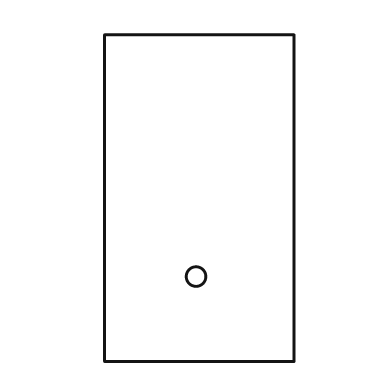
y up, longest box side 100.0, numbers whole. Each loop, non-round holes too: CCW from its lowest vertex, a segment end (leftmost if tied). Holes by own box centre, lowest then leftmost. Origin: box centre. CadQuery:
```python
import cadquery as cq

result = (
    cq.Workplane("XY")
    .moveTo(-29.0, -50.0)
    .lineTo(29.0, -50.0)
    .lineTo(29.0, 50.0)
    .lineTo(-29.0, 50.0)
    .close()
    .moveTo(-1.0, -24.0)
    .circle(3.0)
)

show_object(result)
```